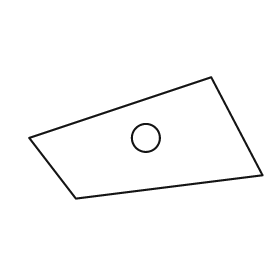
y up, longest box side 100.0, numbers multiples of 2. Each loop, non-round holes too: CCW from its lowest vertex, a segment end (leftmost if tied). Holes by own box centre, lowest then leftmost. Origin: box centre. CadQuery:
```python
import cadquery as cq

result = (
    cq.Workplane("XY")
    .moveTo(-30.0, -26.0)
    .lineTo(50.0, -16.0)
    .lineTo(28.0, 26.0)
    .lineTo(-50.0, 0.0)
    .close()
    .moveTo(0.0, 0.0)
    .circle(6.0)
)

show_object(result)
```